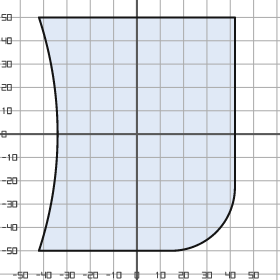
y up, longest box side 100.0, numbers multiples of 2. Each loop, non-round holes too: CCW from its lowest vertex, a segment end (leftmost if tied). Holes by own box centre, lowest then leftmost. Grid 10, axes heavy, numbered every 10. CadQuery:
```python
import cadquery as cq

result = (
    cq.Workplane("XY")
    .moveTo(-42.0, -50.0)
    .lineTo(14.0, -50.0)
    .threePointArc((34.0, -42.0), (42.0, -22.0))
    .lineTo(42.0, 50.0)
    .lineTo(-42.0, 50.0)
    .threePointArc((-34.0, 0.0), (-42.0, -50.0))
    .close()
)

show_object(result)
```